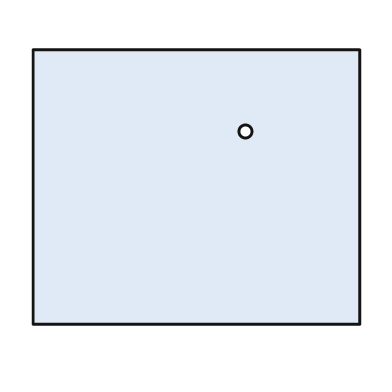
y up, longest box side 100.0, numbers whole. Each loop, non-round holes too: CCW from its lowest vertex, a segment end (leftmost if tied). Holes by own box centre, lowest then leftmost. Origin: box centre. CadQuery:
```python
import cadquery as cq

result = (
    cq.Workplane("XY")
    .moveTo(-50.0, -42.0)
    .lineTo(50.0, -42.0)
    .lineTo(50.0, 42.0)
    .lineTo(-50.0, 42.0)
    .close()
    .moveTo(15.0, 17.0)
    .circle(2.0)
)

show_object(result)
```